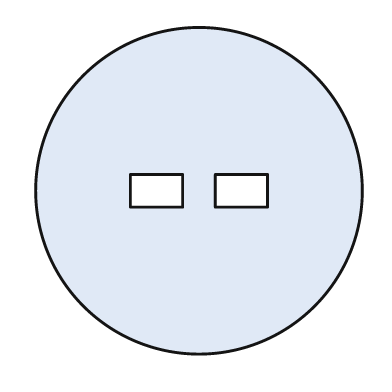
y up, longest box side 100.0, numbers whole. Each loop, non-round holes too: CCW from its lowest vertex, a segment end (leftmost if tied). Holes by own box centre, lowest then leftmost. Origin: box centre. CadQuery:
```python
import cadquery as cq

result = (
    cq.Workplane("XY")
    .moveTo(0.0, 0.0)
    .circle(50.0)
    .moveTo(-21.0, -5.0)
    .lineTo(-5.0, -5.0)
    .lineTo(-5.0, 5.0)
    .lineTo(-21.0, 5.0)
    .close()
    .moveTo(5.0, -5.0)
    .lineTo(21.0, -5.0)
    .lineTo(21.0, 5.0)
    .lineTo(5.0, 5.0)
    .close()
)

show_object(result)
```